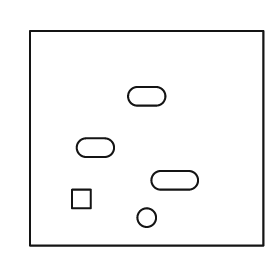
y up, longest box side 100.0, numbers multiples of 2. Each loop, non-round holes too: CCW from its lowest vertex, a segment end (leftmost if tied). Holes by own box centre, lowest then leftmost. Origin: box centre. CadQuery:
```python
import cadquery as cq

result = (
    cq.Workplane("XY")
    .moveTo(-50.0, -46.0)
    .lineTo(50.0, -46.0)
    .lineTo(50.0, 46.0)
    .lineTo(-50.0, 46.0)
    .close()
    .moveTo(0.0, -34.0)
    .circle(4.0)
    .moveTo(-32.0, -30.0)
    .lineTo(-24.0, -30.0)
    .lineTo(-24.0, -22.0)
    .lineTo(-32.0, -22.0)
    .close()
    .moveTo(6.0, -22.0)
    .lineTo(18.0, -22.0)
    .threePointArc((22.0, -18.0), (18.0, -14.0))
    .lineTo(6.0, -14.0)
    .threePointArc((2.0, -18.0), (6.0, -22.0))
    .close()
    .moveTo(-26.0, -8.0)
    .lineTo(-18.0, -8.0)
    .threePointArc((-14.0, -4.0), (-18.0, 0.0))
    .lineTo(-26.0, 0.0)
    .threePointArc((-30.0, -4.0), (-26.0, -8.0))
    .close()
    .moveTo(-4.0, 14.0)
    .lineTo(4.0, 14.0)
    .threePointArc((8.0, 18.0), (4.0, 22.0))
    .lineTo(-4.0, 22.0)
    .threePointArc((-8.0, 18.0), (-4.0, 14.0))
    .close()
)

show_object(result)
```